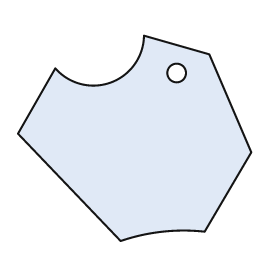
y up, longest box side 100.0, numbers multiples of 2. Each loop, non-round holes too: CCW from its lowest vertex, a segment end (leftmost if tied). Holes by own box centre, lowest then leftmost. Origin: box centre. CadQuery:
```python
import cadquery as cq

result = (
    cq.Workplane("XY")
    .moveTo(-6.0, -44.0)
    .threePointArc((12.0, -40.0), (30.0, -40.0))
    .lineTo(50.0, -6.0)
    .lineTo(32.0, 36.0)
    .lineTo(4.0, 44.0)
    .threePointArc((-10.0, 24.0), (-34.0, 30.0))
    .lineTo(-50.0, 2.0)
    .close()
    .moveTo(18.0, 28.0)
    .circle(4.0)
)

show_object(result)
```